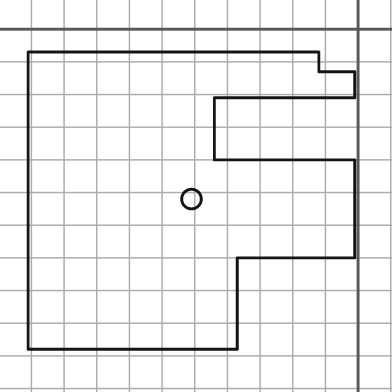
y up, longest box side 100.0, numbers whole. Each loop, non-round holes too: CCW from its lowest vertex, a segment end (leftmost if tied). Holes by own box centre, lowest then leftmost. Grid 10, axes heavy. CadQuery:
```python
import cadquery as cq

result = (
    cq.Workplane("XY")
    .moveTo(-101.0, -98.0)
    .lineTo(-37.0, -98.0)
    .lineTo(-37.0, -70.0)
    .lineTo(-1.0, -70.0)
    .lineTo(-1.0, -40.0)
    .lineTo(-44.0, -40.0)
    .lineTo(-44.0, -21.0)
    .lineTo(-1.0, -21.0)
    .lineTo(-1.0, -13.0)
    .lineTo(-12.0, -13.0)
    .lineTo(-12.0, -7.0)
    .lineTo(-101.0, -7.0)
    .close()
    .moveTo(-51.0, -52.0)
    .circle(3.0)
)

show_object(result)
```